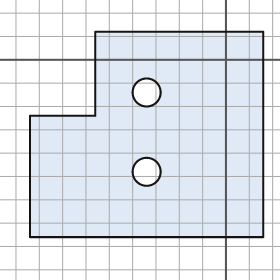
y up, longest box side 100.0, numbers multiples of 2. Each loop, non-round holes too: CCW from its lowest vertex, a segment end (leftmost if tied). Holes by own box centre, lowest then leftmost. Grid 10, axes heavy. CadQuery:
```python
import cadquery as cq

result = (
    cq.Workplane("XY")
    .moveTo(-84.0, -76.0)
    .lineTo(16.0, -76.0)
    .lineTo(16.0, 12.0)
    .lineTo(-56.0, 12.0)
    .lineTo(-56.0, -24.0)
    .lineTo(-84.0, -24.0)
    .close()
    .moveTo(-34.0, -48.0)
    .circle(6.0)
    .moveTo(-34.0, -14.0)
    .circle(6.0)
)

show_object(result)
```